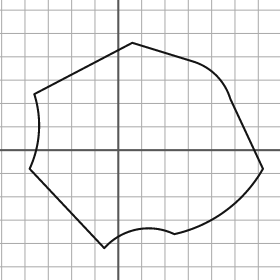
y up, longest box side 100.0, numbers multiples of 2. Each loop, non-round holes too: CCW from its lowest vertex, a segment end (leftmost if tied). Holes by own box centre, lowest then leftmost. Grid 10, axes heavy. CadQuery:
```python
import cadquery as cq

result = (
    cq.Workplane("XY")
    .moveTo(-6.0, -42.0)
    .threePointArc((8.0, -34.0), (24.0, -36.0))
    .threePointArc((46.0, -26.0), (62.0, -8.0))
    .lineTo(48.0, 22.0)
    .threePointArc((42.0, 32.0), (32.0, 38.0))
    .lineTo(6.0, 46.0)
    .lineTo(-36.0, 24.0)
    .threePointArc((-34.0, 8.0), (-38.0, -8.0))
    .close()
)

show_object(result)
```